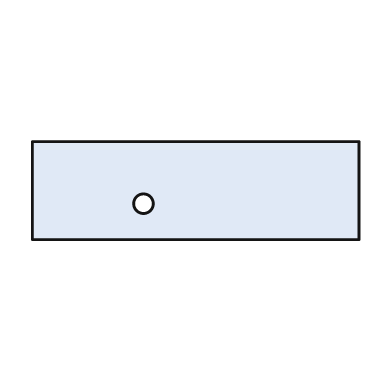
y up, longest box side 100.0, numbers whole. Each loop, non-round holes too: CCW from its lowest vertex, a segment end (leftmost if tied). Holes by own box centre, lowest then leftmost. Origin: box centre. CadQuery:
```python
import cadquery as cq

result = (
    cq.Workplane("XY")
    .moveTo(-50.0, -15.0)
    .lineTo(50.0, -15.0)
    .lineTo(50.0, 15.0)
    .lineTo(-50.0, 15.0)
    .close()
    .moveTo(-16.0, -4.0)
    .circle(3.0)
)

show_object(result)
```